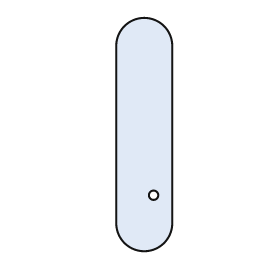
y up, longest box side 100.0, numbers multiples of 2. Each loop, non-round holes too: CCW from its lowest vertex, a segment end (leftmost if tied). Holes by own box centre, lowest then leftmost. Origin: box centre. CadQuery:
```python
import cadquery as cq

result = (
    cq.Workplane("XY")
    .moveTo(-12.0, -38.0)
    .threePointArc((0.0, -50.0), (12.0, -38.0))
    .lineTo(12.0, 38.0)
    .threePointArc((0.0, 50.0), (-12.0, 38.0))
    .close()
    .moveTo(4.0, -26.0)
    .circle(2.0)
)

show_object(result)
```